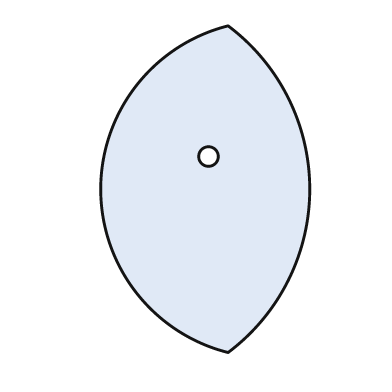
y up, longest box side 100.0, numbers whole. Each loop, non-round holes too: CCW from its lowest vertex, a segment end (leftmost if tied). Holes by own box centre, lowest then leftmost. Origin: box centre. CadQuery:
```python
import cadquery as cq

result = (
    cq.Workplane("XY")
    .moveTo(7.0, -50.0)
    .threePointArc((32.0, 0.0), (7.0, 50.0))
    .threePointArc((-32.0, 0.0), (7.0, -50.0))
    .close()
    .moveTo(1.0, 10.0)
    .circle(3.0)
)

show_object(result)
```